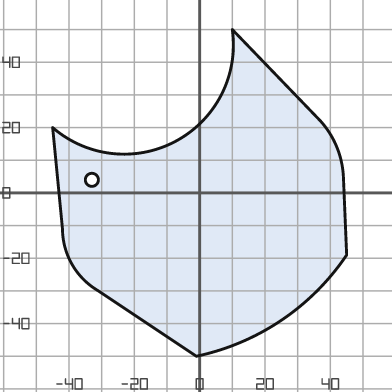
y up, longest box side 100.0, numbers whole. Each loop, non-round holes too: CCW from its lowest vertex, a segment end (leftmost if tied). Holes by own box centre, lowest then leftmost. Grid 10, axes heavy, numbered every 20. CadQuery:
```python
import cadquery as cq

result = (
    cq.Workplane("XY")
    .moveTo(-1.0, -50.0)
    .threePointArc((25.0, -39.0), (45.0, -19.0))
    .lineTo(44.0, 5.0)
    .threePointArc((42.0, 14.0), (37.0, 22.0))
    .lineTo(10.0, 50.0)
    .threePointArc((-7.0, 16.0), (-45.0, 20.0))
    .lineTo(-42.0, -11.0)
    .threePointArc((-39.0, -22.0), (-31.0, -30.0))
    .close()
    .moveTo(-33.0, 4.0)
    .circle(2.0)
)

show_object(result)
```